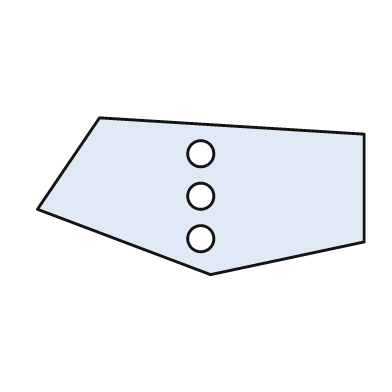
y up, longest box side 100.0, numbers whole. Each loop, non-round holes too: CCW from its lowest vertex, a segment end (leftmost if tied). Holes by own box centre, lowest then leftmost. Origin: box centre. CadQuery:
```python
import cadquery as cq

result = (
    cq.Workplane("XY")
    .moveTo(3.0, -24.0)
    .lineTo(50.0, -14.0)
    .lineTo(50.0, 19.0)
    .lineTo(-31.0, 24.0)
    .lineTo(-50.0, -4.0)
    .close()
    .moveTo(0.0, -13.0)
    .circle(4.0)
    .moveTo(0.0, 0.0)
    .circle(4.0)
    .moveTo(0.0, 13.0)
    .circle(4.0)
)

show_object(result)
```